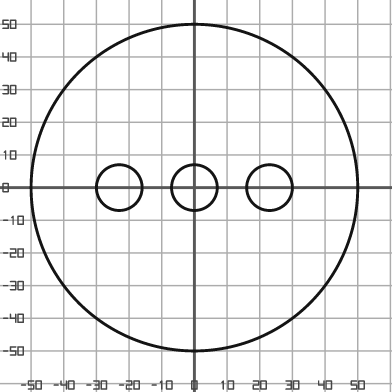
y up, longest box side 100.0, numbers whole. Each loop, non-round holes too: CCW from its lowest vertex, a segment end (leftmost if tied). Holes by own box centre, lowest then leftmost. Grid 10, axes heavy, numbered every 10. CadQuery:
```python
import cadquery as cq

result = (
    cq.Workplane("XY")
    .moveTo(0.0, 0.0)
    .circle(50.0)
    .moveTo(-23.0, 0.0)
    .circle(7.0)
    .moveTo(0.0, 0.0)
    .circle(7.0)
    .moveTo(23.0, 0.0)
    .circle(7.0)
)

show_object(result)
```